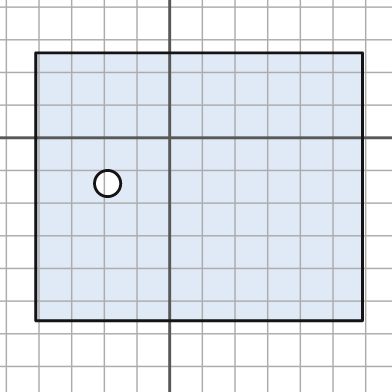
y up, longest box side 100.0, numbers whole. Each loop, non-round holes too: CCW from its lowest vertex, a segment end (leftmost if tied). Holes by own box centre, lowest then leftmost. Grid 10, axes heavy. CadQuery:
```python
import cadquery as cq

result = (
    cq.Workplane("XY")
    .moveTo(-41.0, -56.0)
    .lineTo(59.0, -56.0)
    .lineTo(59.0, 26.0)
    .lineTo(-41.0, 26.0)
    .close()
    .moveTo(-19.0, -14.0)
    .circle(4.0)
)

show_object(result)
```